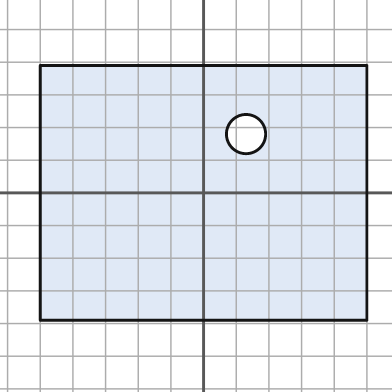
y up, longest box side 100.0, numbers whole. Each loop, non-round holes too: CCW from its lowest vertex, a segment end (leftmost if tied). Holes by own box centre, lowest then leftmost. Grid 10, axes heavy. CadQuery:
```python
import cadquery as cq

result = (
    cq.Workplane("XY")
    .moveTo(-50.0, -39.0)
    .lineTo(50.0, -39.0)
    .lineTo(50.0, 39.0)
    .lineTo(-50.0, 39.0)
    .close()
    .moveTo(13.0, 18.0)
    .circle(6.0)
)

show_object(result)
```